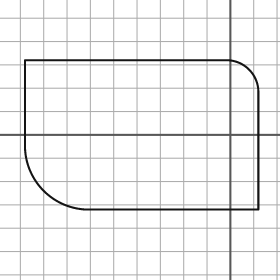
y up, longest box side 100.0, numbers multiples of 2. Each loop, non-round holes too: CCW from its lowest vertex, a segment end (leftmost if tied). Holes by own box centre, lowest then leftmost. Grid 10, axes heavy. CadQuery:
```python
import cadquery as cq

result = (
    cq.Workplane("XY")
    .moveTo(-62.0, -32.0)
    .lineTo(12.0, -32.0)
    .lineTo(12.0, 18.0)
    .threePointArc((8.0, 28.0), (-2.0, 32.0))
    .lineTo(-88.0, 32.0)
    .lineTo(-88.0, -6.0)
    .threePointArc((-80.0, -24.0), (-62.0, -32.0))
    .close()
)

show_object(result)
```